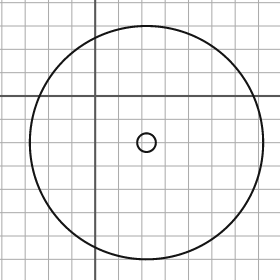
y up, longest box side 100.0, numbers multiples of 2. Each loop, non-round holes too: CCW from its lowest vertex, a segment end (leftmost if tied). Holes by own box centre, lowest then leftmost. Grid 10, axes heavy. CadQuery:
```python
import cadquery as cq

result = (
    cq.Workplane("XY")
    .moveTo(22.0, -20.0)
    .circle(50.0)
    .moveTo(22.0, -20.0)
    .circle(4.0)
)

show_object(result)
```